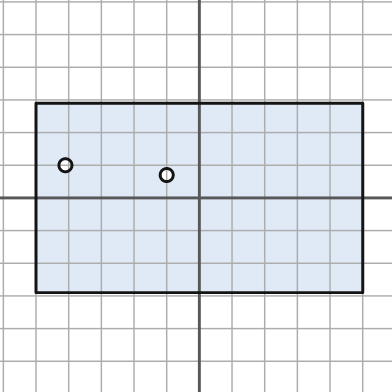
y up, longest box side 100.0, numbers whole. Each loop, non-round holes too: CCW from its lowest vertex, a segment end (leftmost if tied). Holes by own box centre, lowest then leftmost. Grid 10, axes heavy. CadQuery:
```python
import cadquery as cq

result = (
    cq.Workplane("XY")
    .moveTo(-50.0, -29.0)
    .lineTo(50.0, -29.0)
    .lineTo(50.0, 29.0)
    .lineTo(-50.0, 29.0)
    .close()
    .moveTo(-10.0, 7.0)
    .circle(2.0)
    .moveTo(-41.0, 10.0)
    .circle(2.0)
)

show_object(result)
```